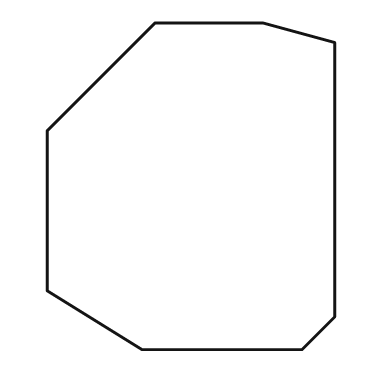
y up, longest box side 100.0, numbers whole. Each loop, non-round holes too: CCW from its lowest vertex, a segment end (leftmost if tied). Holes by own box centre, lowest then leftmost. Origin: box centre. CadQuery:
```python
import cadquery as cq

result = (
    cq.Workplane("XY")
    .moveTo(-15.0, -50.0)
    .lineTo(34.0, -50.0)
    .lineTo(44.0, -40.0)
    .lineTo(44.0, 44.0)
    .lineTo(22.0, 50.0)
    .lineTo(-11.0, 50.0)
    .lineTo(-44.0, 17.0)
    .lineTo(-44.0, -32.0)
    .close()
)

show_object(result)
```